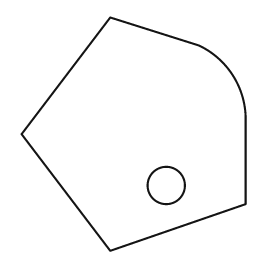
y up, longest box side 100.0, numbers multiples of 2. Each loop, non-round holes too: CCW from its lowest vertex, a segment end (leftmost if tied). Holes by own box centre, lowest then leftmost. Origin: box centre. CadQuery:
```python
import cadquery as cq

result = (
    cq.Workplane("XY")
    .moveTo(-10.0, -50.0)
    .lineTo(48.0, -30.0)
    .lineTo(48.0, 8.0)
    .threePointArc((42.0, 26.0), (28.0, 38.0))
    .lineTo(-10.0, 50.0)
    .lineTo(-48.0, 0.0)
    .close()
    .moveTo(14.0, -22.0)
    .circle(8.0)
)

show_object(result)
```